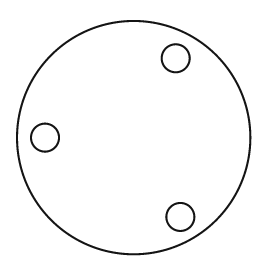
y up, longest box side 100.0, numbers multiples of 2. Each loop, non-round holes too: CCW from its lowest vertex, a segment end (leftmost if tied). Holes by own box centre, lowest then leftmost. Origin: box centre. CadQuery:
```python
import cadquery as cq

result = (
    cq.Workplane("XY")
    .moveTo(0.0, 0.0)
    .circle(50.0)
    .moveTo(20.0, -34.0)
    .circle(6.0)
    .moveTo(-38.0, 0.0)
    .circle(6.0)
    .moveTo(18.0, 34.0)
    .circle(6.0)
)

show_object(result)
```